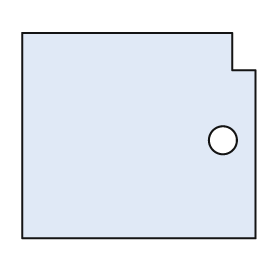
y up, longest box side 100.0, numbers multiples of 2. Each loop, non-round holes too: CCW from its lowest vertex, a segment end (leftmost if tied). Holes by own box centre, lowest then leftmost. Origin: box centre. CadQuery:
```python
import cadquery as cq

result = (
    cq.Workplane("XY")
    .moveTo(-50.0, -44.0)
    .lineTo(50.0, -44.0)
    .lineTo(50.0, 28.0)
    .lineTo(40.0, 28.0)
    .lineTo(40.0, 44.0)
    .lineTo(-50.0, 44.0)
    .close()
    .moveTo(36.0, -2.0)
    .circle(6.0)
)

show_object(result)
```